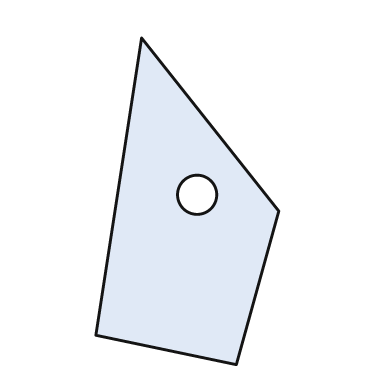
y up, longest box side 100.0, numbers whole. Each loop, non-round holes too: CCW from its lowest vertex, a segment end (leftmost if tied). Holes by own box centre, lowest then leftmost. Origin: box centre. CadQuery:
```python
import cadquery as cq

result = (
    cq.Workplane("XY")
    .moveTo(15.0, -50.0)
    .lineTo(28.0, -3.0)
    .lineTo(-14.0, 50.0)
    .lineTo(-28.0, -41.0)
    .close()
    .moveTo(3.0, 2.0)
    .circle(6.0)
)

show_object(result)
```